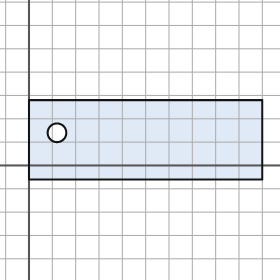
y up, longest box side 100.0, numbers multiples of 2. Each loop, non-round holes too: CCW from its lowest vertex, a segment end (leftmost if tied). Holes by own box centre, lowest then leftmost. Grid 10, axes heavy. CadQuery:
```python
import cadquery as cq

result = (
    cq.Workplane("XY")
    .moveTo(0.0, -6.0)
    .lineTo(100.0, -6.0)
    .lineTo(100.0, 28.0)
    .lineTo(0.0, 28.0)
    .close()
    .moveTo(12.0, 14.0)
    .circle(4.0)
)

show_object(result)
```